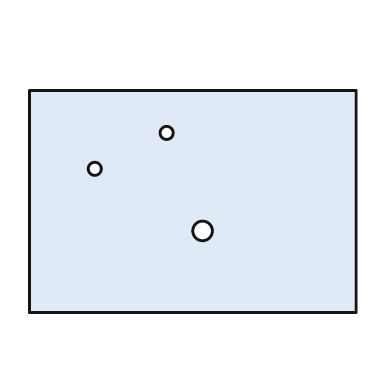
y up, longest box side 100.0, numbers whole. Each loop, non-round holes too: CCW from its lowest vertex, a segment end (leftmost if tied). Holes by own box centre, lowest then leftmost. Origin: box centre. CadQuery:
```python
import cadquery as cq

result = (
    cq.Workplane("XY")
    .moveTo(-50.0, -34.0)
    .lineTo(50.0, -34.0)
    .lineTo(50.0, 34.0)
    .lineTo(-50.0, 34.0)
    .close()
    .moveTo(3.0, -9.0)
    .circle(3.0)
    .moveTo(-30.0, 10.0)
    .circle(2.0)
    .moveTo(-8.0, 21.0)
    .circle(2.0)
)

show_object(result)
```